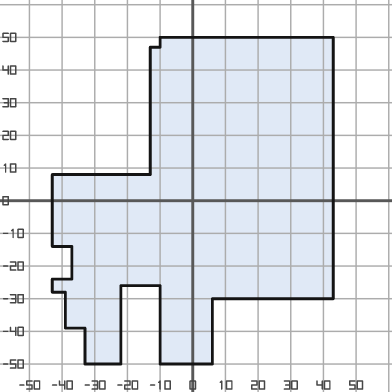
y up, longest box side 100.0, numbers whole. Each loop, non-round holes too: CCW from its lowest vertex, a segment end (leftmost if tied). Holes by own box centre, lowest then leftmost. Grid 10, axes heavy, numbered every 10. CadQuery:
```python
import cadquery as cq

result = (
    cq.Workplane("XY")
    .moveTo(-33.0, -50.0)
    .lineTo(-22.0, -50.0)
    .lineTo(-22.0, -26.0)
    .lineTo(-10.0, -26.0)
    .lineTo(-10.0, -50.0)
    .lineTo(6.0, -50.0)
    .lineTo(6.0, -30.0)
    .lineTo(43.0, -30.0)
    .lineTo(43.0, 50.0)
    .lineTo(-10.0, 50.0)
    .lineTo(-10.0, 47.0)
    .lineTo(-13.0, 47.0)
    .lineTo(-13.0, 8.0)
    .lineTo(-43.0, 8.0)
    .lineTo(-43.0, -14.0)
    .lineTo(-37.0, -14.0)
    .lineTo(-37.0, -24.0)
    .lineTo(-43.0, -24.0)
    .lineTo(-43.0, -28.0)
    .lineTo(-39.0, -28.0)
    .lineTo(-39.0, -39.0)
    .lineTo(-33.0, -39.0)
    .close()
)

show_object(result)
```